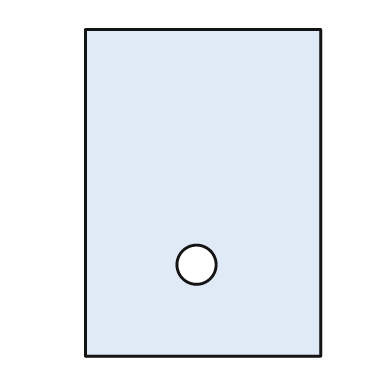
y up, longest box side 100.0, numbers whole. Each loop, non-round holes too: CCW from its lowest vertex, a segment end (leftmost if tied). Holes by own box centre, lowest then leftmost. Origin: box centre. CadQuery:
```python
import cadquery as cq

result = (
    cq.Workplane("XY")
    .moveTo(-36.0, -50.0)
    .lineTo(36.0, -50.0)
    .lineTo(36.0, 50.0)
    .lineTo(-36.0, 50.0)
    .close()
    .moveTo(-2.0, -22.0)
    .circle(6.0)
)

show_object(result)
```